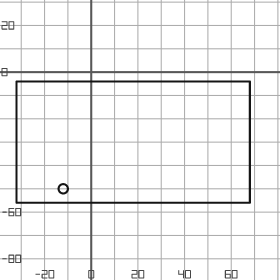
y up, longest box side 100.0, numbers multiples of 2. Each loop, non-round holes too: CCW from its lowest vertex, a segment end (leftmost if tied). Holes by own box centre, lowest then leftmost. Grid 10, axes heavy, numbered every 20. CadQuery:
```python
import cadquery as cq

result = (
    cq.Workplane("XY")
    .moveTo(-32.0, -56.0)
    .lineTo(68.0, -56.0)
    .lineTo(68.0, -4.0)
    .lineTo(-32.0, -4.0)
    .close()
    .moveTo(-12.0, -50.0)
    .circle(2.0)
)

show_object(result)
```